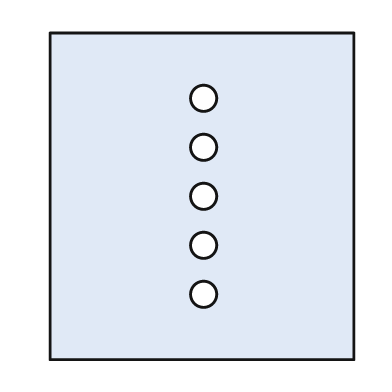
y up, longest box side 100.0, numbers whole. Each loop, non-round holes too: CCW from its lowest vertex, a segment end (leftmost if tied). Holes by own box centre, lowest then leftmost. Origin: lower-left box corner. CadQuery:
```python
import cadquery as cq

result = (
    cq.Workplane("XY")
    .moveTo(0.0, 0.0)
    .lineTo(93.0, 0.0)
    .lineTo(93.0, 100.0)
    .lineTo(0.0, 100.0)
    .close()
    .moveTo(47.0, 20.0)
    .circle(4.0)
    .moveTo(47.0, 35.0)
    .circle(4.0)
    .moveTo(47.0, 50.0)
    .circle(4.0)
    .moveTo(47.0, 65.0)
    .circle(4.0)
    .moveTo(47.0, 80.0)
    .circle(4.0)
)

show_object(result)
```